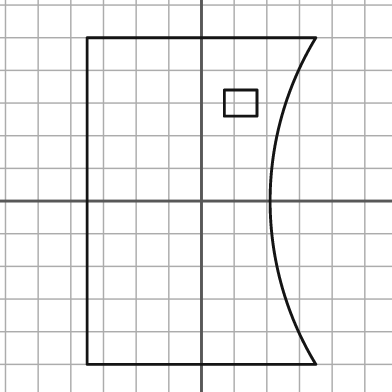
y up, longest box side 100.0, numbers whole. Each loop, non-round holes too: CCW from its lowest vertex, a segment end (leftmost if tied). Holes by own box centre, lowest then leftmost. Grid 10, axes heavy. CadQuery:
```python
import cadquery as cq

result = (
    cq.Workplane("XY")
    .moveTo(-35.0, -50.0)
    .lineTo(35.0, -50.0)
    .threePointArc((21.0, 0.0), (35.0, 50.0))
    .lineTo(-35.0, 50.0)
    .close()
    .moveTo(7.0, 26.0)
    .lineTo(17.0, 26.0)
    .lineTo(17.0, 34.0)
    .lineTo(7.0, 34.0)
    .close()
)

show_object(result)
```